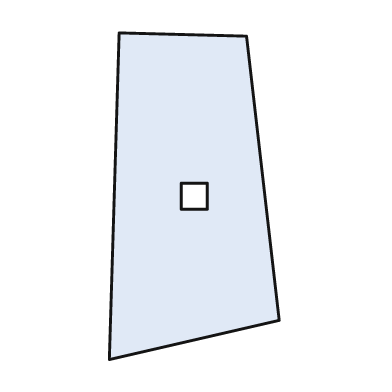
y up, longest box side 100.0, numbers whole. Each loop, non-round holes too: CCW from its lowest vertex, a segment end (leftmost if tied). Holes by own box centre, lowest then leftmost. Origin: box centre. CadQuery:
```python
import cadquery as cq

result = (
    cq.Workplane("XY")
    .moveTo(-26.0, -50.0)
    .lineTo(26.0, -38.0)
    .lineTo(16.0, 49.0)
    .lineTo(-23.0, 50.0)
    .close()
    .moveTo(-4.0, -4.0)
    .lineTo(4.0, -4.0)
    .lineTo(4.0, 4.0)
    .lineTo(-4.0, 4.0)
    .close()
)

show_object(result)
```